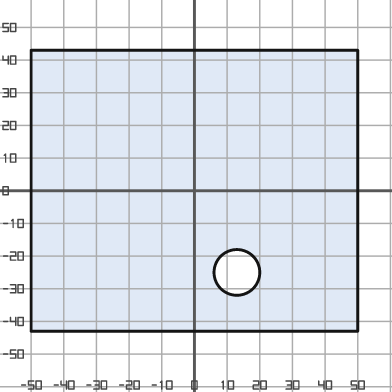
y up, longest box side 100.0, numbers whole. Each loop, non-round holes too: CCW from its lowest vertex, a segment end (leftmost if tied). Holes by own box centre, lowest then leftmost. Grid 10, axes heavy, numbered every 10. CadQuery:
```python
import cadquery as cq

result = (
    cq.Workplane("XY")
    .moveTo(-50.0, -43.0)
    .lineTo(50.0, -43.0)
    .lineTo(50.0, 43.0)
    .lineTo(-50.0, 43.0)
    .close()
    .moveTo(13.0, -25.0)
    .circle(7.0)
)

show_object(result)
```